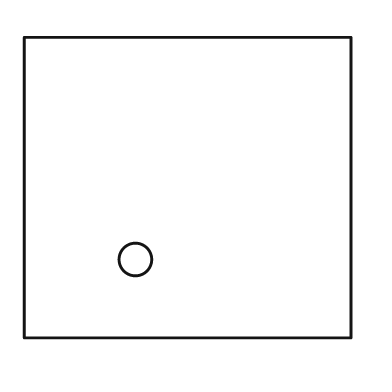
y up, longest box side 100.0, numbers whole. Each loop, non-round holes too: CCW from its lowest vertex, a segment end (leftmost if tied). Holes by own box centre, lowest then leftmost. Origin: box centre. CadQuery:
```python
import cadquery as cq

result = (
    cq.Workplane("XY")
    .moveTo(-50.0, -46.0)
    .lineTo(50.0, -46.0)
    .lineTo(50.0, 46.0)
    .lineTo(-50.0, 46.0)
    .close()
    .moveTo(-16.0, -22.0)
    .circle(5.0)
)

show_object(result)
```